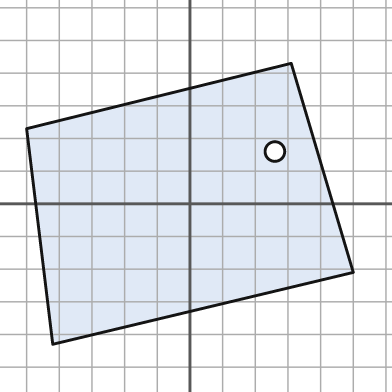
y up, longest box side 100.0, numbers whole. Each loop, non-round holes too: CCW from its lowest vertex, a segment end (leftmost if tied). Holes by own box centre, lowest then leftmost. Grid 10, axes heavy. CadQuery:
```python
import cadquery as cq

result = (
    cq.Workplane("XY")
    .moveTo(-42.0, -43.0)
    .lineTo(50.0, -21.0)
    .lineTo(31.0, 43.0)
    .lineTo(-50.0, 23.0)
    .close()
    .moveTo(26.0, 16.0)
    .circle(3.0)
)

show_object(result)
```